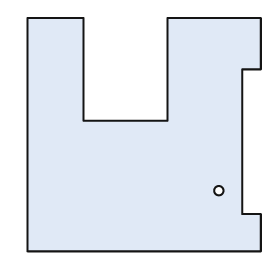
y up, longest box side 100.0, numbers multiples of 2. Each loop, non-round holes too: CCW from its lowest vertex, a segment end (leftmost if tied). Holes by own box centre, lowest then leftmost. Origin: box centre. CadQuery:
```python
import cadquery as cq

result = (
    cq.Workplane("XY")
    .moveTo(-50.0, -50.0)
    .lineTo(50.0, -50.0)
    .lineTo(50.0, -34.0)
    .lineTo(42.0, -34.0)
    .lineTo(42.0, 28.0)
    .lineTo(50.0, 28.0)
    .lineTo(50.0, 50.0)
    .lineTo(10.0, 50.0)
    .lineTo(10.0, 6.0)
    .lineTo(-26.0, 6.0)
    .lineTo(-26.0, 50.0)
    .lineTo(-50.0, 50.0)
    .close()
    .moveTo(32.0, -24.0)
    .circle(2.0)
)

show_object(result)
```